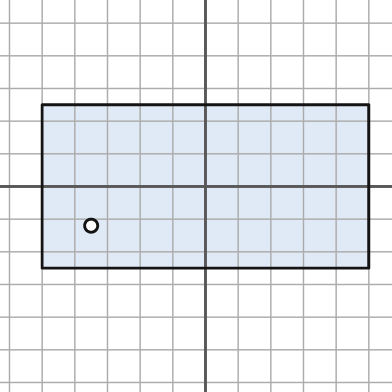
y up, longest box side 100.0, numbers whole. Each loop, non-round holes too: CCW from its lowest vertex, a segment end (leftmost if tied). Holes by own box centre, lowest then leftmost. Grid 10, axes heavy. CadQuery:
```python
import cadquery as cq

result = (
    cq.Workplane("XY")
    .moveTo(-50.0, -25.0)
    .lineTo(50.0, -25.0)
    .lineTo(50.0, 25.0)
    .lineTo(-50.0, 25.0)
    .close()
    .moveTo(-35.0, -12.0)
    .circle(2.0)
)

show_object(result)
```